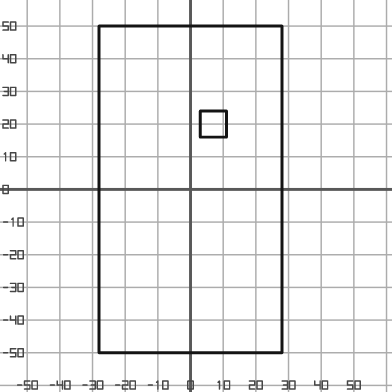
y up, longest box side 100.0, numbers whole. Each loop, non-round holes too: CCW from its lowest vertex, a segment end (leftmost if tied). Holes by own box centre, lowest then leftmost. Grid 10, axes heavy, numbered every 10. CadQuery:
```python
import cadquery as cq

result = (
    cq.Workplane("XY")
    .moveTo(-28.0, -50.0)
    .lineTo(28.0, -50.0)
    .lineTo(28.0, 50.0)
    .lineTo(-28.0, 50.0)
    .close()
    .moveTo(3.0, 16.0)
    .lineTo(11.0, 16.0)
    .lineTo(11.0, 24.0)
    .lineTo(3.0, 24.0)
    .close()
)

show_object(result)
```